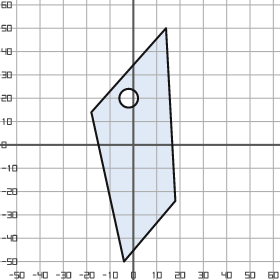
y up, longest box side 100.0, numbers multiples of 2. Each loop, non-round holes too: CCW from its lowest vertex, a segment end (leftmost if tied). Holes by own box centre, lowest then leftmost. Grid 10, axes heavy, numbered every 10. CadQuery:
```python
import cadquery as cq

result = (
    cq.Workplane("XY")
    .moveTo(-4.0, -50.0)
    .lineTo(18.0, -24.0)
    .lineTo(14.0, 50.0)
    .lineTo(-18.0, 14.0)
    .close()
    .moveTo(-2.0, 20.0)
    .circle(4.0)
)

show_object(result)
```